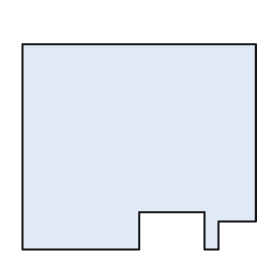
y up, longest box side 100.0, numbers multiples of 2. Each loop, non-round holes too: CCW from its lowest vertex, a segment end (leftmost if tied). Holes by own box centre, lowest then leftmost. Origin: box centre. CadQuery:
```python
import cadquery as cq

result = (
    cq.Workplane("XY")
    .moveTo(-50.0, -44.0)
    .lineTo(0.0, -44.0)
    .lineTo(0.0, -28.0)
    .lineTo(28.0, -28.0)
    .lineTo(28.0, -44.0)
    .lineTo(34.0, -44.0)
    .lineTo(34.0, -32.0)
    .lineTo(50.0, -32.0)
    .lineTo(50.0, 44.0)
    .lineTo(-50.0, 44.0)
    .close()
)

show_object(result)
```